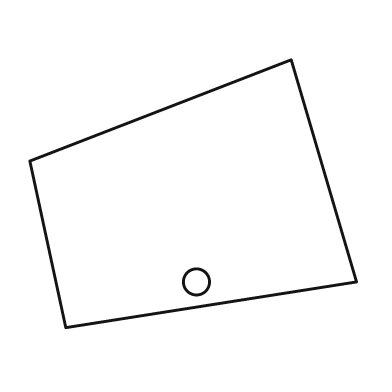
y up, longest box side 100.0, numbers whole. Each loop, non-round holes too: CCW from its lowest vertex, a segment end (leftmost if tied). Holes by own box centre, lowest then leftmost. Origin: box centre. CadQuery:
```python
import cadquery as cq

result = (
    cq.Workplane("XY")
    .moveTo(-39.0, -41.0)
    .lineTo(50.0, -27.0)
    .lineTo(30.0, 41.0)
    .lineTo(-50.0, 10.0)
    .close()
    .moveTo(1.0, -27.0)
    .circle(4.0)
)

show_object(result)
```